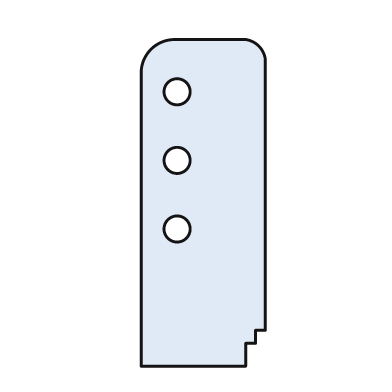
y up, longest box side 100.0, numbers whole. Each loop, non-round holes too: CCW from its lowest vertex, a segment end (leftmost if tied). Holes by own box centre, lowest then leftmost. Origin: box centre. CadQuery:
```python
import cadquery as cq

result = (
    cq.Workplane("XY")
    .moveTo(-19.0, -50.0)
    .lineTo(13.0, -50.0)
    .lineTo(13.0, -43.0)
    .lineTo(16.0, -43.0)
    .lineTo(16.0, -39.0)
    .lineTo(19.0, -39.0)
    .lineTo(19.0, 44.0)
    .threePointArc((17.0, 48.0), (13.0, 50.0))
    .lineTo(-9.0, 50.0)
    .threePointArc((-16.0, 47.0), (-19.0, 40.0))
    .close()
    .moveTo(-8.0, -8.0)
    .circle(4.0)
    .moveTo(-8.0, 13.0)
    .circle(4.0)
    .moveTo(-8.0, 34.0)
    .circle(4.0)
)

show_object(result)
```